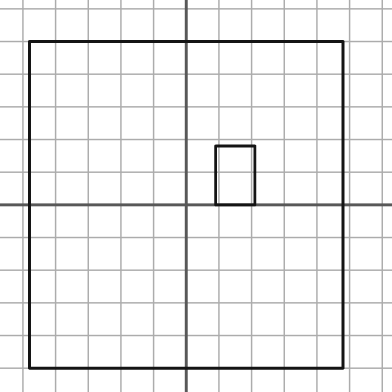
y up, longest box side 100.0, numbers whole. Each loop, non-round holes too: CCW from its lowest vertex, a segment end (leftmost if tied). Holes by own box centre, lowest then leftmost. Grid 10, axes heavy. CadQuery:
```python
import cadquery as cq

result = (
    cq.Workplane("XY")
    .moveTo(-48.0, -50.0)
    .lineTo(48.0, -50.0)
    .lineTo(48.0, 50.0)
    .lineTo(-48.0, 50.0)
    .close()
    .moveTo(9.0, 0.0)
    .lineTo(21.0, 0.0)
    .lineTo(21.0, 18.0)
    .lineTo(9.0, 18.0)
    .close()
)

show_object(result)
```